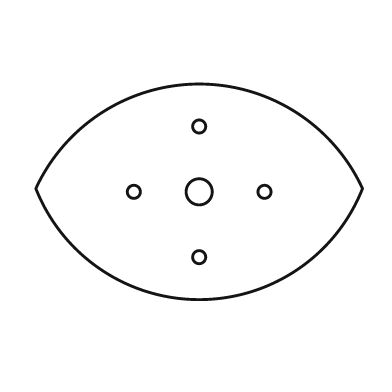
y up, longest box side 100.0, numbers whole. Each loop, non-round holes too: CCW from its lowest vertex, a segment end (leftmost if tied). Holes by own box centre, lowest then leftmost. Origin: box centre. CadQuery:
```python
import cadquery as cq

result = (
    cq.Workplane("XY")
    .moveTo(-50.0, 1.0)
    .threePointArc((0.0, -33.0), (50.0, 1.0))
    .threePointArc((0.0, 33.0), (-50.0, 1.0))
    .close()
    .moveTo(0.0, -20.0)
    .circle(2.0)
    .moveTo(-20.0, 0.0)
    .circle(2.0)
    .moveTo(0.0, 0.0)
    .circle(4.0)
    .moveTo(20.0, 0.0)
    .circle(2.0)
    .moveTo(0.0, 20.0)
    .circle(2.0)
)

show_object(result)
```